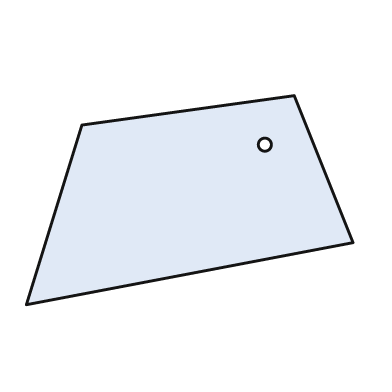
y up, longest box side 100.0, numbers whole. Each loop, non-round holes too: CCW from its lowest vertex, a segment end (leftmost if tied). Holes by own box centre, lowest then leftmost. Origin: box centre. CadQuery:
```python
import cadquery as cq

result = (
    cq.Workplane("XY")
    .moveTo(-50.0, -32.0)
    .lineTo(50.0, -13.0)
    .lineTo(32.0, 32.0)
    .lineTo(-33.0, 23.0)
    .close()
    .moveTo(23.0, 17.0)
    .circle(2.0)
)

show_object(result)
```